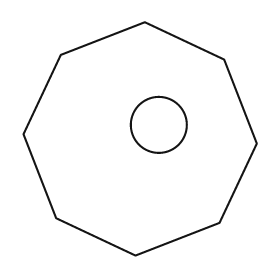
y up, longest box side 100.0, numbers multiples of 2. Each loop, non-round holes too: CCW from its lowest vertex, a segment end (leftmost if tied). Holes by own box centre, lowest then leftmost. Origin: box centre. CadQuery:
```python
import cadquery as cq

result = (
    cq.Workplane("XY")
    .moveTo(-2.0, -50.0)
    .lineTo(34.0, -36.0)
    .lineTo(50.0, -2.0)
    .lineTo(36.0, 34.0)
    .lineTo(2.0, 50.0)
    .lineTo(-34.0, 36.0)
    .lineTo(-50.0, 2.0)
    .lineTo(-36.0, -34.0)
    .close()
    .moveTo(8.0, 6.0)
    .circle(12.0)
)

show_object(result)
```